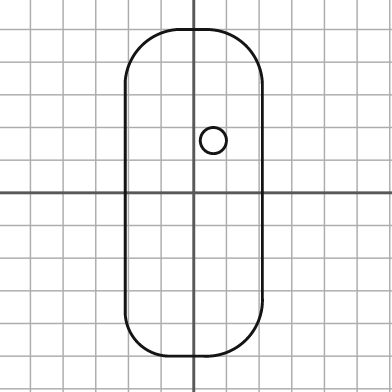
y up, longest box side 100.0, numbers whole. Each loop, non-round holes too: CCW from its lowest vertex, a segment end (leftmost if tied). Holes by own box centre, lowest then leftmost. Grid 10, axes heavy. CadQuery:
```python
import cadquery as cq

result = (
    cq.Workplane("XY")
    .moveTo(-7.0, -50.0)
    .lineTo(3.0, -50.0)
    .threePointArc((16.0, -45.0), (21.0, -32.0))
    .lineTo(21.0, 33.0)
    .threePointArc((16.0, 45.0), (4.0, 50.0))
    .lineTo(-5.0, 50.0)
    .threePointArc((-16.0, 45.0), (-21.0, 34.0))
    .lineTo(-21.0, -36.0)
    .threePointArc((-17.0, -46.0), (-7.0, -50.0))
    .close()
    .moveTo(6.0, 16.0)
    .circle(4.0)
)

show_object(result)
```